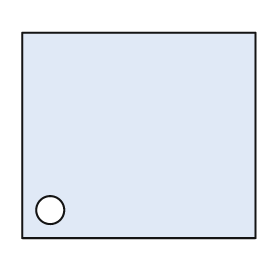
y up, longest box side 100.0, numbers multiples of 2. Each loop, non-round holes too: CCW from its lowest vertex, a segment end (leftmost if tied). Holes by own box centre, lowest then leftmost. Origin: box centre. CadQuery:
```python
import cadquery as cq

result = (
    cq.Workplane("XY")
    .moveTo(-50.0, -44.0)
    .lineTo(50.0, -44.0)
    .lineTo(50.0, 44.0)
    .lineTo(-50.0, 44.0)
    .close()
    .moveTo(-38.0, -32.0)
    .circle(6.0)
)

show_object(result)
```